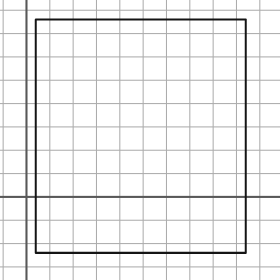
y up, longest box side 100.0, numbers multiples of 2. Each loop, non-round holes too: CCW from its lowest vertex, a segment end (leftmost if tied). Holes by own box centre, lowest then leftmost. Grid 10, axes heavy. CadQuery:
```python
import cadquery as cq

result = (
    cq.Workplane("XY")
    .moveTo(4.0, -24.0)
    .lineTo(94.0, -24.0)
    .lineTo(94.0, 76.0)
    .lineTo(4.0, 76.0)
    .close()
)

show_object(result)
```